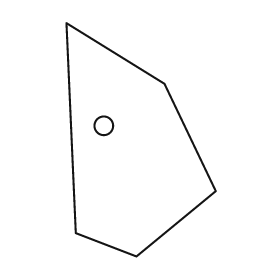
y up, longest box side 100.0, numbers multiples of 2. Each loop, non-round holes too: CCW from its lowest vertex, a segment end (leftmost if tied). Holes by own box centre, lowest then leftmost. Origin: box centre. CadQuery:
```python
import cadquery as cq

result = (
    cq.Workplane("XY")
    .moveTo(-2.0, -50.0)
    .lineTo(32.0, -22.0)
    .lineTo(10.0, 24.0)
    .lineTo(-32.0, 50.0)
    .lineTo(-28.0, -40.0)
    .close()
    .moveTo(-16.0, 6.0)
    .circle(4.0)
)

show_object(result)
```